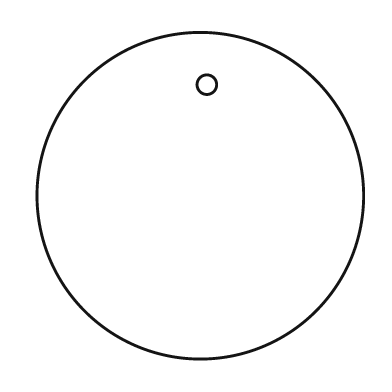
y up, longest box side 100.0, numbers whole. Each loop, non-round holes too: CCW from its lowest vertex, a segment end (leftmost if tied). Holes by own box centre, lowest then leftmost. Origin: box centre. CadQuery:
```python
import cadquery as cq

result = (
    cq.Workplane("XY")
    .moveTo(0.0, 0.0)
    .circle(50.0)
    .moveTo(2.0, 34.0)
    .circle(3.0)
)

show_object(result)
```